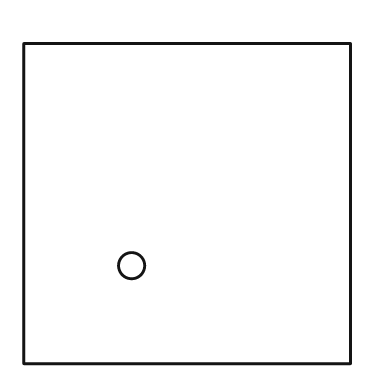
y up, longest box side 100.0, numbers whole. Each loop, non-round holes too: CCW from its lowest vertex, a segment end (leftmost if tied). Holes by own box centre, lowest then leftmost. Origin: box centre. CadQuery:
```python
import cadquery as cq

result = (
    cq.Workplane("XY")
    .moveTo(-50.0, -49.0)
    .lineTo(50.0, -49.0)
    .lineTo(50.0, 49.0)
    .lineTo(-50.0, 49.0)
    .close()
    .moveTo(-17.0, -19.0)
    .circle(4.0)
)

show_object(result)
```